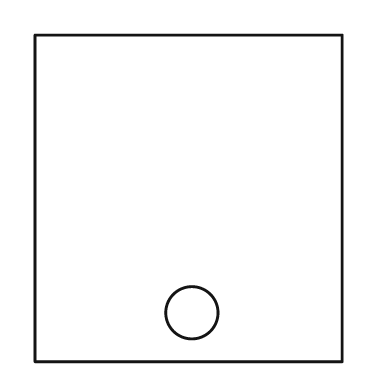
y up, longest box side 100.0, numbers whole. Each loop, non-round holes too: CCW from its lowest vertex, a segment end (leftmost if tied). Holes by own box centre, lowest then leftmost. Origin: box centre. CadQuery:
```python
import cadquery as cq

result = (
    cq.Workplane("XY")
    .moveTo(-47.0, -50.0)
    .lineTo(47.0, -50.0)
    .lineTo(47.0, 50.0)
    .lineTo(-47.0, 50.0)
    .close()
    .moveTo(1.0, -35.0)
    .circle(8.0)
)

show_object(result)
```